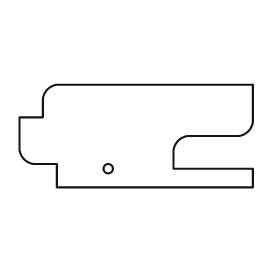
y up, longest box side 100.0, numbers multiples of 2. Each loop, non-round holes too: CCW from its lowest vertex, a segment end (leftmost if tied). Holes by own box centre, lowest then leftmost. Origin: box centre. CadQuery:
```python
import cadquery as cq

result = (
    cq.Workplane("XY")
    .moveTo(-34.0, -22.0)
    .lineTo(50.0, -22.0)
    .lineTo(50.0, -14.0)
    .lineTo(16.0, -14.0)
    .lineTo(16.0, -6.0)
    .threePointArc((18.0, -2.0), (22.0, 0.0))
    .lineTo(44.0, 0.0)
    .threePointArc((48.0, 2.0), (50.0, 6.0))
    .lineTo(50.0, 22.0)
    .lineTo(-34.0, 22.0)
    .threePointArc((-38.0, 20.0), (-40.0, 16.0))
    .lineTo(-40.0, 8.0)
    .lineTo(-50.0, 8.0)
    .lineTo(-50.0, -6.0)
    .threePointArc((-48.0, -10.0), (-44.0, -12.0))
    .lineTo(-34.0, -12.0)
    .close()
    .moveTo(-12.0, -14.0)
    .circle(2.0)
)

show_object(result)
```